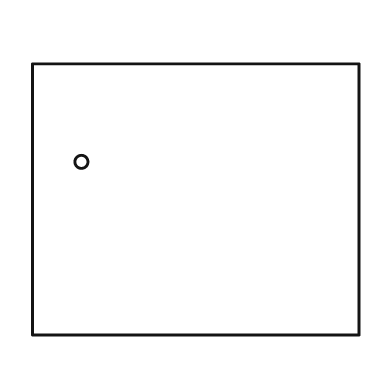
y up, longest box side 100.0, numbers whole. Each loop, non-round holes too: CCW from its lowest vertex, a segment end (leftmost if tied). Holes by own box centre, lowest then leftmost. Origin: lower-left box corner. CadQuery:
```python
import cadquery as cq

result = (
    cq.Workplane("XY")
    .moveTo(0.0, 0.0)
    .lineTo(100.0, 0.0)
    .lineTo(100.0, 83.0)
    .lineTo(0.0, 83.0)
    .close()
    .moveTo(15.0, 53.0)
    .circle(2.0)
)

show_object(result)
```